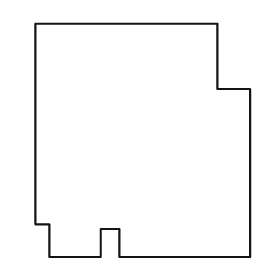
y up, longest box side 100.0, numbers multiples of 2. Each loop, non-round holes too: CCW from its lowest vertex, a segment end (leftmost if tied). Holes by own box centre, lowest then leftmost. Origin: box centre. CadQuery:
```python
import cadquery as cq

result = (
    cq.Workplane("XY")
    .moveTo(-40.0, -50.0)
    .lineTo(-18.0, -50.0)
    .lineTo(-18.0, -38.0)
    .lineTo(-10.0, -38.0)
    .lineTo(-10.0, -50.0)
    .lineTo(46.0, -50.0)
    .lineTo(46.0, 22.0)
    .lineTo(32.0, 22.0)
    .lineTo(32.0, 50.0)
    .lineTo(-46.0, 50.0)
    .lineTo(-46.0, -36.0)
    .lineTo(-40.0, -36.0)
    .close()
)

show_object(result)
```